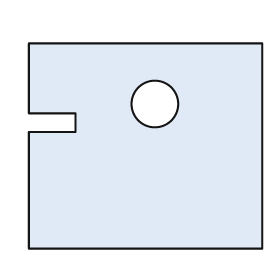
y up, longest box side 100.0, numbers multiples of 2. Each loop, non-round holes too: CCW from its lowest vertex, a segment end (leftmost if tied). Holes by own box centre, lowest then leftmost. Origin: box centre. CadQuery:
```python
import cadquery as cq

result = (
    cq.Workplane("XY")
    .moveTo(-50.0, -44.0)
    .lineTo(50.0, -44.0)
    .lineTo(50.0, 44.0)
    .lineTo(-50.0, 44.0)
    .lineTo(-50.0, 14.0)
    .lineTo(-30.0, 14.0)
    .lineTo(-30.0, 6.0)
    .lineTo(-50.0, 6.0)
    .close()
    .moveTo(4.0, 18.0)
    .circle(10.0)
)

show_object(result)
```